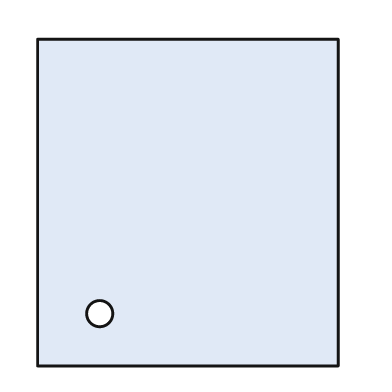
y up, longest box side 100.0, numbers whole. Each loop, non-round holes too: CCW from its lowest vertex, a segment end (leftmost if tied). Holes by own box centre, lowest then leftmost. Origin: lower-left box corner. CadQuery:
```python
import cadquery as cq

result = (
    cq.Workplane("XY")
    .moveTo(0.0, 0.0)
    .lineTo(92.0, 0.0)
    .lineTo(92.0, 100.0)
    .lineTo(0.0, 100.0)
    .close()
    .moveTo(19.0, 16.0)
    .circle(4.0)
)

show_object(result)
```